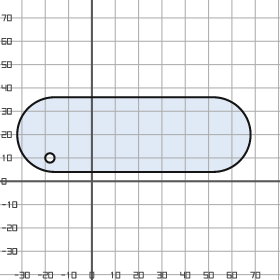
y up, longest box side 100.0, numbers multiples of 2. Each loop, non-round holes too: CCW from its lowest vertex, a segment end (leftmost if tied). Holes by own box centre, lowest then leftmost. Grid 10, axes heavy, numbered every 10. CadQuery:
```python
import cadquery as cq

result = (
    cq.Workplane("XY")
    .moveTo(-16.0, 4.0)
    .lineTo(52.0, 4.0)
    .threePointArc((68.0, 20.0), (52.0, 36.0))
    .lineTo(-16.0, 36.0)
    .threePointArc((-32.0, 20.0), (-16.0, 4.0))
    .close()
    .moveTo(-18.0, 10.0)
    .circle(2.0)
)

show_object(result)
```